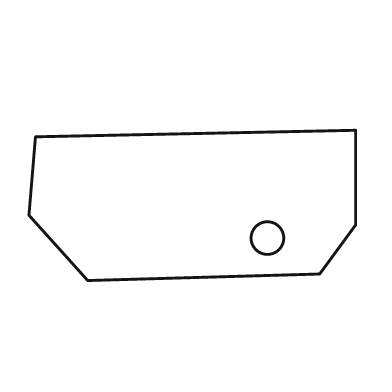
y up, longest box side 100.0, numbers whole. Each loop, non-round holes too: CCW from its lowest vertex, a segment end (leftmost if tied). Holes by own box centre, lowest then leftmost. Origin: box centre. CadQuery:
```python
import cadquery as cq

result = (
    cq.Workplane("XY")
    .moveTo(-32.0, -23.0)
    .lineTo(39.0, -21.0)
    .lineTo(50.0, -6.0)
    .lineTo(50.0, 23.0)
    .lineTo(-48.0, 21.0)
    .lineTo(-50.0, -3.0)
    .close()
    .moveTo(23.0, -10.0)
    .circle(5.0)
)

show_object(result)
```